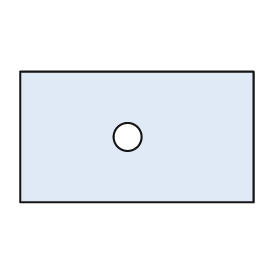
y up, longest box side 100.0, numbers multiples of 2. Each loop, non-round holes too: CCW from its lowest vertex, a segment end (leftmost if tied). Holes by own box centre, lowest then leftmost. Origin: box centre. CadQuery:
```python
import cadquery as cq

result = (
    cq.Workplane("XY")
    .moveTo(-50.0, -28.0)
    .lineTo(50.0, -28.0)
    .lineTo(50.0, 28.0)
    .lineTo(-50.0, 28.0)
    .close()
    .moveTo(-4.0, 0.0)
    .circle(6.0)
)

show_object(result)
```